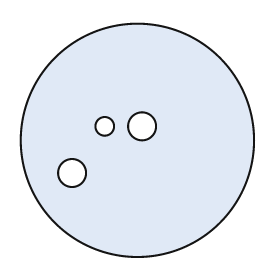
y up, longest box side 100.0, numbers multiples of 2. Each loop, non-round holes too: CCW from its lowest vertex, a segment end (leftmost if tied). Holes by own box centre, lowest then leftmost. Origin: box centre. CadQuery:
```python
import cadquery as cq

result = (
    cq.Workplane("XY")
    .moveTo(0.0, 0.0)
    .circle(50.0)
    .moveTo(-28.0, -14.0)
    .circle(6.0)
    .moveTo(-14.0, 6.0)
    .circle(4.0)
    .moveTo(2.0, 6.0)
    .circle(6.0)
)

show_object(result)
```